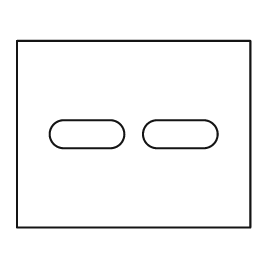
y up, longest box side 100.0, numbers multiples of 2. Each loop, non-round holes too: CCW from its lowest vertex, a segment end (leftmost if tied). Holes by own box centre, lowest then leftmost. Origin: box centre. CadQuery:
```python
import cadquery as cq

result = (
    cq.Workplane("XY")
    .moveTo(-50.0, -40.0)
    .lineTo(50.0, -40.0)
    .lineTo(50.0, 40.0)
    .lineTo(-50.0, 40.0)
    .close()
    .moveTo(-30.0, -6.0)
    .lineTo(-10.0, -6.0)
    .threePointArc((-4.0, 0.0), (-10.0, 6.0))
    .lineTo(-30.0, 6.0)
    .threePointArc((-36.0, 0.0), (-30.0, -6.0))
    .close()
    .moveTo(10.0, -6.0)
    .lineTo(30.0, -6.0)
    .threePointArc((36.0, 0.0), (30.0, 6.0))
    .lineTo(10.0, 6.0)
    .threePointArc((4.0, 0.0), (10.0, -6.0))
    .close()
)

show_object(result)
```